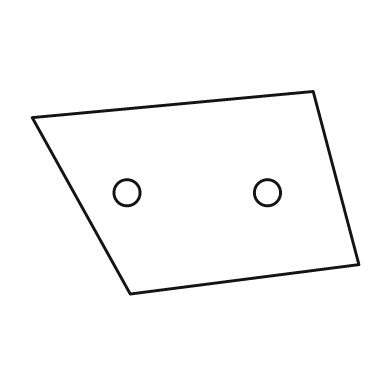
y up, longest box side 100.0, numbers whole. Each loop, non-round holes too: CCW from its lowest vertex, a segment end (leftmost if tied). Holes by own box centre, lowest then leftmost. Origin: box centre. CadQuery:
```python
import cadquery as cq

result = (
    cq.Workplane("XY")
    .moveTo(-20.0, -31.0)
    .lineTo(50.0, -22.0)
    .lineTo(36.0, 31.0)
    .lineTo(-50.0, 23.0)
    .close()
    .moveTo(-21.0, 0.0)
    .circle(4.0)
    .moveTo(22.0, 0.0)
    .circle(4.0)
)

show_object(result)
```